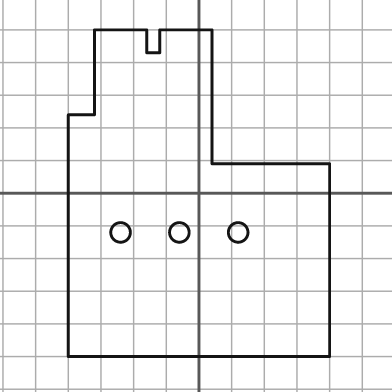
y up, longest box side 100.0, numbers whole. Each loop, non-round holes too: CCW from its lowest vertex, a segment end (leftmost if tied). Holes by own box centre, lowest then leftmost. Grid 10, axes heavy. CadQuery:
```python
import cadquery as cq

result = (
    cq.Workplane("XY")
    .moveTo(-40.0, -50.0)
    .lineTo(40.0, -50.0)
    .lineTo(40.0, 9.0)
    .lineTo(4.0, 9.0)
    .lineTo(4.0, 50.0)
    .lineTo(-12.0, 50.0)
    .lineTo(-12.0, 43.0)
    .lineTo(-16.0, 43.0)
    .lineTo(-16.0, 50.0)
    .lineTo(-32.0, 50.0)
    .lineTo(-32.0, 24.0)
    .lineTo(-40.0, 24.0)
    .close()
    .moveTo(-24.0, -12.0)
    .circle(3.0)
    .moveTo(-6.0, -12.0)
    .circle(3.0)
    .moveTo(12.0, -12.0)
    .circle(3.0)
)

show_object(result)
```